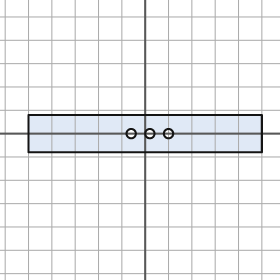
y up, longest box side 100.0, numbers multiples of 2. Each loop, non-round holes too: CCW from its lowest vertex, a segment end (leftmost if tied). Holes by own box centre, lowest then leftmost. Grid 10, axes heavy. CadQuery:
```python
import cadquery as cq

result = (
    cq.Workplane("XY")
    .moveTo(-50.0, -8.0)
    .lineTo(50.0, -8.0)
    .lineTo(50.0, 8.0)
    .lineTo(-50.0, 8.0)
    .close()
    .moveTo(-6.0, 0.0)
    .circle(2.0)
    .moveTo(2.0, 0.0)
    .circle(2.0)
    .moveTo(10.0, 0.0)
    .circle(2.0)
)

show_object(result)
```